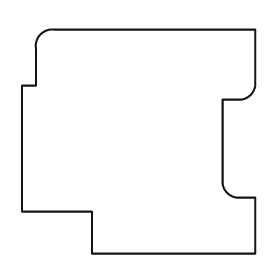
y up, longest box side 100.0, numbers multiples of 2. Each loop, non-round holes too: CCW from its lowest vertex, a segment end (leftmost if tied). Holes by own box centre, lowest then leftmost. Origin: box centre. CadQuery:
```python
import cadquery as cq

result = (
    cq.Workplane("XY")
    .moveTo(-20.0, -48.0)
    .lineTo(50.0, -48.0)
    .lineTo(50.0, -24.0)
    .lineTo(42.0, -24.0)
    .threePointArc((38.0, -22.0), (36.0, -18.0))
    .lineTo(36.0, 18.0)
    .lineTo(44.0, 18.0)
    .threePointArc((48.0, 20.0), (50.0, 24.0))
    .lineTo(50.0, 48.0)
    .lineTo(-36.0, 48.0)
    .threePointArc((-42.0, 46.0), (-44.0, 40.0))
    .lineTo(-44.0, 24.0)
    .lineTo(-50.0, 24.0)
    .lineTo(-50.0, -30.0)
    .lineTo(-20.0, -30.0)
    .close()
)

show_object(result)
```